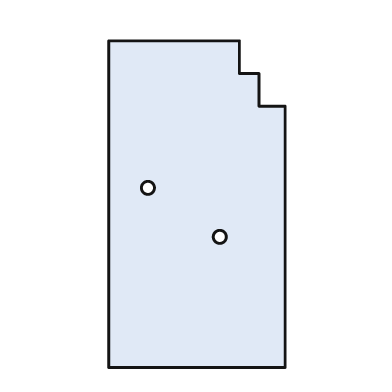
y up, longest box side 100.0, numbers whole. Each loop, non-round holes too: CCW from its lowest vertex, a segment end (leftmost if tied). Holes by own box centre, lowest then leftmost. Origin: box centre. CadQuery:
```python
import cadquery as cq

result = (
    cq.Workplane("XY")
    .moveTo(-27.0, -50.0)
    .lineTo(27.0, -50.0)
    .lineTo(27.0, 30.0)
    .lineTo(19.0, 30.0)
    .lineTo(19.0, 40.0)
    .lineTo(13.0, 40.0)
    .lineTo(13.0, 50.0)
    .lineTo(-27.0, 50.0)
    .close()
    .moveTo(7.0, -10.0)
    .circle(2.0)
    .moveTo(-15.0, 5.0)
    .circle(2.0)
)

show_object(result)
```